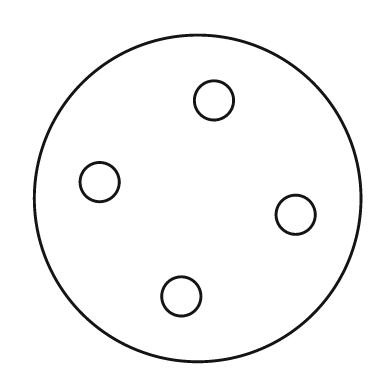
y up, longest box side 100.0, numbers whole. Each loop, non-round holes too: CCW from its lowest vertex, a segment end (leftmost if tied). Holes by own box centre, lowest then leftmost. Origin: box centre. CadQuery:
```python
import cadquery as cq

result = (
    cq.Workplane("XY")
    .moveTo(0.0, 0.0)
    .circle(50.0)
    .moveTo(-5.0, -30.0)
    .circle(6.0)
    .moveTo(30.0, -5.0)
    .circle(6.0)
    .moveTo(-30.0, 5.0)
    .circle(6.0)
    .moveTo(5.0, 30.0)
    .circle(6.0)
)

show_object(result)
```